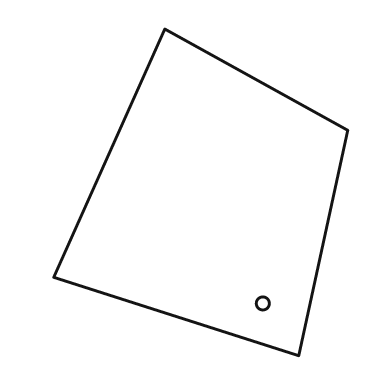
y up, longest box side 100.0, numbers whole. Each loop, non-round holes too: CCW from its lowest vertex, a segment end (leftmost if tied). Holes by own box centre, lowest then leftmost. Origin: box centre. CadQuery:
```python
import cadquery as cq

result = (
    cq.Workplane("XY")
    .moveTo(30.0, -50.0)
    .lineTo(45.0, 19.0)
    .lineTo(-11.0, 50.0)
    .lineTo(-45.0, -26.0)
    .close()
    .moveTo(19.0, -34.0)
    .circle(2.0)
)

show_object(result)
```